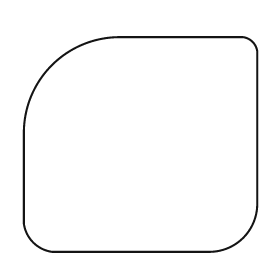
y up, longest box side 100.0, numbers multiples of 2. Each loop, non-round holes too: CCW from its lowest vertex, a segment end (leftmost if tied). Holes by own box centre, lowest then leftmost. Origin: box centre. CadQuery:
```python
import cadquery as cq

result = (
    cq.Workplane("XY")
    .moveTo(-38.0, -46.0)
    .lineTo(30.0, -46.0)
    .threePointArc((44.0, -40.0), (50.0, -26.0))
    .lineTo(50.0, 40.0)
    .threePointArc((48.0, 44.0), (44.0, 46.0))
    .lineTo(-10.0, 46.0)
    .threePointArc((-38.0, 34.0), (-50.0, 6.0))
    .lineTo(-50.0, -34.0)
    .threePointArc((-46.0, -42.0), (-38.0, -46.0))
    .close()
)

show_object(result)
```